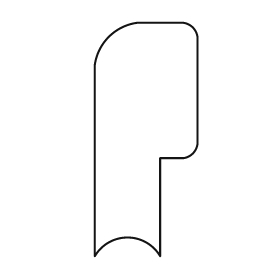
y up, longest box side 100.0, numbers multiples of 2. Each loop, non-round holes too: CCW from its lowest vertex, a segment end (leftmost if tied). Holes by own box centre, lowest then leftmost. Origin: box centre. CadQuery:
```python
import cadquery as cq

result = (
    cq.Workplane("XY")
    .moveTo(-22.0, -50.0)
    .threePointArc((-8.0, -42.0), (6.0, -50.0))
    .lineTo(6.0, -8.0)
    .lineTo(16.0, -8.0)
    .threePointArc((20.0, -6.0), (22.0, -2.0))
    .lineTo(22.0, 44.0)
    .threePointArc((20.0, 48.0), (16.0, 50.0))
    .lineTo(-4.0, 50.0)
    .threePointArc((-16.0, 44.0), (-22.0, 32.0))
    .close()
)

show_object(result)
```